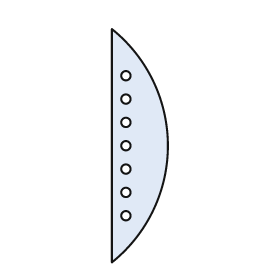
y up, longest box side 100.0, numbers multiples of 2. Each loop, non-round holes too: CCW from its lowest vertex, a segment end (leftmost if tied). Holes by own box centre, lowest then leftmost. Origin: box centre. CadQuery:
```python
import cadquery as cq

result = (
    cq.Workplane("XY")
    .moveTo(-12.0, -50.0)
    .threePointArc((12.0, 0.0), (-12.0, 50.0))
    .close()
    .moveTo(-6.0, -30.0)
    .circle(2.0)
    .moveTo(-6.0, -20.0)
    .circle(2.0)
    .moveTo(-6.0, -10.0)
    .circle(2.0)
    .moveTo(-6.0, 0.0)
    .circle(2.0)
    .moveTo(-6.0, 10.0)
    .circle(2.0)
    .moveTo(-6.0, 20.0)
    .circle(2.0)
    .moveTo(-6.0, 30.0)
    .circle(2.0)
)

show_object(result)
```